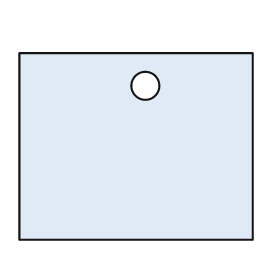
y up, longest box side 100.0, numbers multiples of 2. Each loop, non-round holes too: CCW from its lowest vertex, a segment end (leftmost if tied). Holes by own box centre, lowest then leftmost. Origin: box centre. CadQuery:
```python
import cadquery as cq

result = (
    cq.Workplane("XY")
    .moveTo(-50.0, -40.0)
    .lineTo(50.0, -40.0)
    .lineTo(50.0, 40.0)
    .lineTo(-50.0, 40.0)
    .close()
    .moveTo(4.0, 26.0)
    .circle(6.0)
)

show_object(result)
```